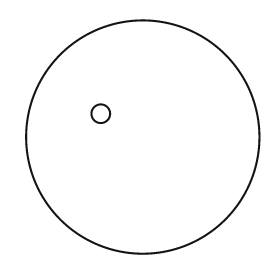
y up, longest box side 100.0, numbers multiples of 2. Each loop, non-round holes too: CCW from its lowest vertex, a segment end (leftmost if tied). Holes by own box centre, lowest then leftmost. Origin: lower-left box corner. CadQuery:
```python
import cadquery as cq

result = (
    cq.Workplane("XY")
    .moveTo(50.0, 50.0)
    .circle(50.0)
    .moveTo(32.0, 60.0)
    .circle(4.0)
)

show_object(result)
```